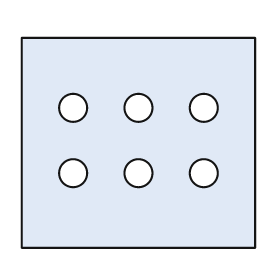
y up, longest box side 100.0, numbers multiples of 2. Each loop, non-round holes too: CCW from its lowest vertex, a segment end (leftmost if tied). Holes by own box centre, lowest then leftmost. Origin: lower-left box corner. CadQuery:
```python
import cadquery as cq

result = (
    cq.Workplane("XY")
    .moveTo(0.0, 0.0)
    .lineTo(100.0, 0.0)
    .lineTo(100.0, 90.0)
    .lineTo(0.0, 90.0)
    .close()
    .moveTo(22.0, 32.0)
    .circle(6.0)
    .moveTo(50.0, 32.0)
    .circle(6.0)
    .moveTo(78.0, 32.0)
    .circle(6.0)
    .moveTo(22.0, 60.0)
    .circle(6.0)
    .moveTo(50.0, 60.0)
    .circle(6.0)
    .moveTo(78.0, 60.0)
    .circle(6.0)
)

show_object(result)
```